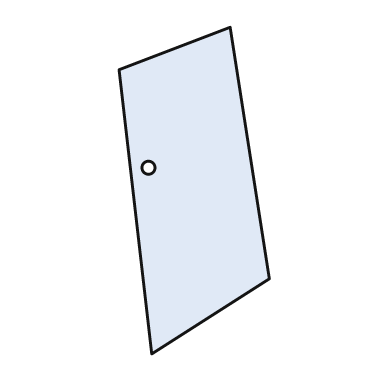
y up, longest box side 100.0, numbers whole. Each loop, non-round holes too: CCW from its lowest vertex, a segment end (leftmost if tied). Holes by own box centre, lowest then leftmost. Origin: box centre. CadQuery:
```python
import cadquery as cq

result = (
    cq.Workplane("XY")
    .moveTo(-13.0, -50.0)
    .lineTo(23.0, -27.0)
    .lineTo(11.0, 50.0)
    .lineTo(-23.0, 37.0)
    .close()
    .moveTo(-14.0, 7.0)
    .circle(2.0)
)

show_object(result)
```